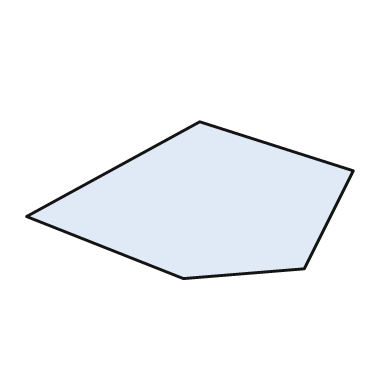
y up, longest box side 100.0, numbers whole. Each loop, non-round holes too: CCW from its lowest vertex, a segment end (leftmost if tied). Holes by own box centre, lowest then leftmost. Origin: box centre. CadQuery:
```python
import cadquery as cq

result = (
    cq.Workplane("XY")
    .moveTo(-2.0, -24.0)
    .lineTo(35.0, -21.0)
    .lineTo(50.0, 9.0)
    .lineTo(3.0, 24.0)
    .lineTo(-50.0, -5.0)
    .close()
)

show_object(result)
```